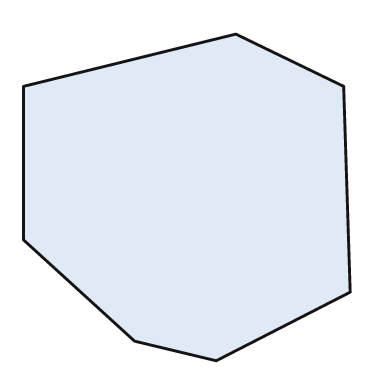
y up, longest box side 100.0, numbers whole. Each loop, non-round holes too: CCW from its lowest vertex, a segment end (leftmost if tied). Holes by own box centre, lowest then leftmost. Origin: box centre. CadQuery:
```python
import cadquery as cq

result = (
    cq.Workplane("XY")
    .moveTo(9.0, -50.0)
    .lineTo(50.0, -29.0)
    .lineTo(48.0, 34.0)
    .lineTo(15.0, 50.0)
    .lineTo(-50.0, 34.0)
    .lineTo(-50.0, -13.0)
    .lineTo(-16.0, -44.0)
    .close()
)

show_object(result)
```